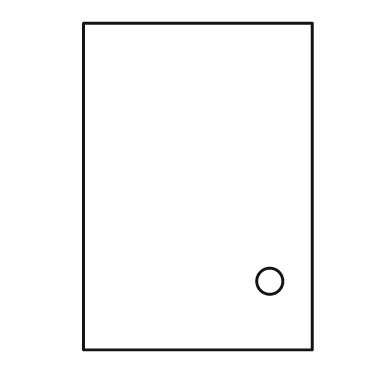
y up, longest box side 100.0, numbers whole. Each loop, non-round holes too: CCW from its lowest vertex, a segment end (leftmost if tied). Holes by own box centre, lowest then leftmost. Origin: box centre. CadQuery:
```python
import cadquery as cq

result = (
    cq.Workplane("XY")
    .moveTo(-35.0, -50.0)
    .lineTo(35.0, -50.0)
    .lineTo(35.0, 50.0)
    .lineTo(-35.0, 50.0)
    .close()
    .moveTo(22.0, -29.0)
    .circle(4.0)
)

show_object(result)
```